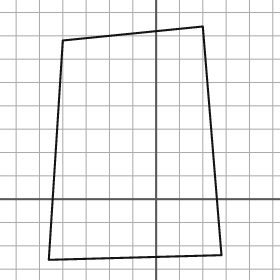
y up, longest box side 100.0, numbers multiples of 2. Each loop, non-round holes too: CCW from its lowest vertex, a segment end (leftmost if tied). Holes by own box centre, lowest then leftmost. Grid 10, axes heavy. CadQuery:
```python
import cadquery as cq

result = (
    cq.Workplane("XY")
    .moveTo(-46.0, -26.0)
    .lineTo(28.0, -24.0)
    .lineTo(20.0, 74.0)
    .lineTo(-40.0, 68.0)
    .close()
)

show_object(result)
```